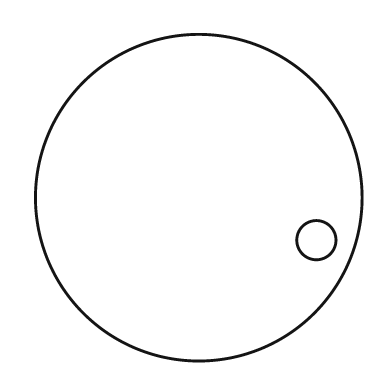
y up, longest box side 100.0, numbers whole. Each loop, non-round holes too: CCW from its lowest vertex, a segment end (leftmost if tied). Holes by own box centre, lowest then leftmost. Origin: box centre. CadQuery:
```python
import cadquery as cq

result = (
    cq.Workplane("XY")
    .moveTo(0.0, 0.0)
    .circle(50.0)
    .moveTo(36.0, -13.0)
    .circle(6.0)
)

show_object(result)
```